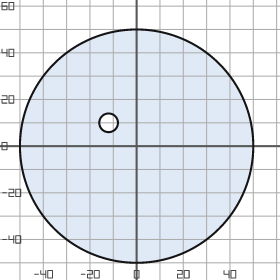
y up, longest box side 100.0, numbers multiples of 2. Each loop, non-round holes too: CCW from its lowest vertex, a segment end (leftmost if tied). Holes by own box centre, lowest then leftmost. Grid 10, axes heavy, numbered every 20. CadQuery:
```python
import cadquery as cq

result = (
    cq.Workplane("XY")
    .moveTo(0.0, 0.0)
    .circle(50.0)
    .moveTo(-12.0, 10.0)
    .circle(4.0)
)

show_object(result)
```